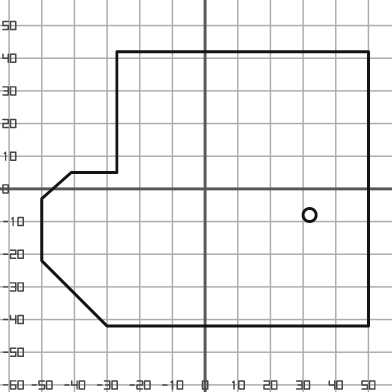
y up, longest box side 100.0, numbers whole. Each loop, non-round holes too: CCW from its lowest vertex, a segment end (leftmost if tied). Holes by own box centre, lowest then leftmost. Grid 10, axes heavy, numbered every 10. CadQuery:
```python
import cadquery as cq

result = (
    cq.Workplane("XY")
    .moveTo(-30.0, -42.0)
    .lineTo(50.0, -42.0)
    .lineTo(50.0, 42.0)
    .lineTo(-27.0, 42.0)
    .lineTo(-27.0, 5.0)
    .lineTo(-41.0, 5.0)
    .lineTo(-50.0, -3.0)
    .lineTo(-50.0, -22.0)
    .close()
    .moveTo(32.0, -8.0)
    .circle(2.0)
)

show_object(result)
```